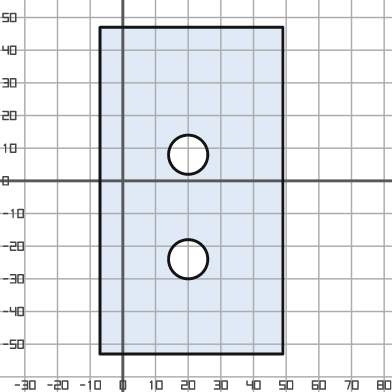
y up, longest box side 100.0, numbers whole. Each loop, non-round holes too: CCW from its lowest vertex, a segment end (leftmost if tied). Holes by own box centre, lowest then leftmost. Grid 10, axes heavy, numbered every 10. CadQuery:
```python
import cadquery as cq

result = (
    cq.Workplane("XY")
    .moveTo(-7.0, -53.0)
    .lineTo(49.0, -53.0)
    .lineTo(49.0, 47.0)
    .lineTo(-7.0, 47.0)
    .close()
    .moveTo(20.0, -24.0)
    .circle(6.0)
    .moveTo(20.0, 8.0)
    .circle(6.0)
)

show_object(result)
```